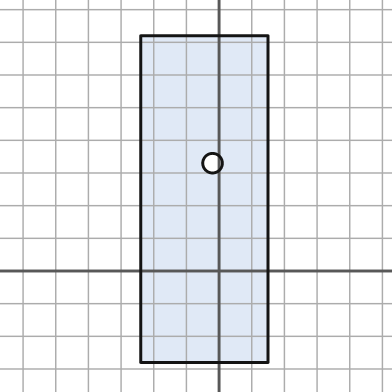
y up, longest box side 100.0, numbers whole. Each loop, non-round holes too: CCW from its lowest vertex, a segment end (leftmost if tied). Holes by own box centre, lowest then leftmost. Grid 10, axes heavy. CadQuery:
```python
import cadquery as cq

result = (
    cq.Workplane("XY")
    .moveTo(-24.0, -28.0)
    .lineTo(15.0, -28.0)
    .lineTo(15.0, 72.0)
    .lineTo(-24.0, 72.0)
    .close()
    .moveTo(-2.0, 33.0)
    .circle(3.0)
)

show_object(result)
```